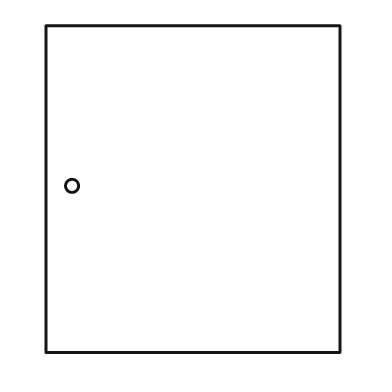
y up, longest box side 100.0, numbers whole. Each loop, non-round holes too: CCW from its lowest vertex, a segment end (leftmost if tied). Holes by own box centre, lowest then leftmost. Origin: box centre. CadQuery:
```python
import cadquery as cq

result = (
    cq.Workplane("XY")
    .moveTo(-45.0, -50.0)
    .lineTo(45.0, -50.0)
    .lineTo(45.0, 50.0)
    .lineTo(-45.0, 50.0)
    .close()
    .moveTo(-37.0, 1.0)
    .circle(2.0)
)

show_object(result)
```